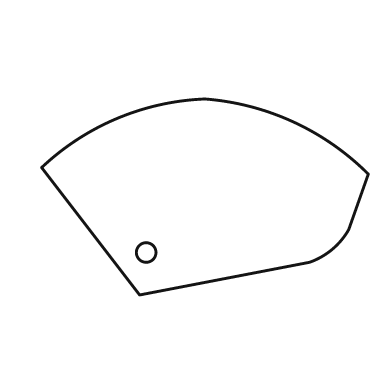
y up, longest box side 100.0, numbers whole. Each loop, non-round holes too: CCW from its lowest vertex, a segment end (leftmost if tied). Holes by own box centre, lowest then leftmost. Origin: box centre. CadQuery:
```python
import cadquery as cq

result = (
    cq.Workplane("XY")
    .moveTo(-20.0, -30.0)
    .lineTo(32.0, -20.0)
    .threePointArc((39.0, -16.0), (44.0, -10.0))
    .lineTo(50.0, 7.0)
    .threePointArc((27.0, 23.0), (0.0, 30.0))
    .threePointArc((-27.0, 24.0), (-50.0, 9.0))
    .close()
    .moveTo(-18.0, -17.0)
    .circle(3.0)
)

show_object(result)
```